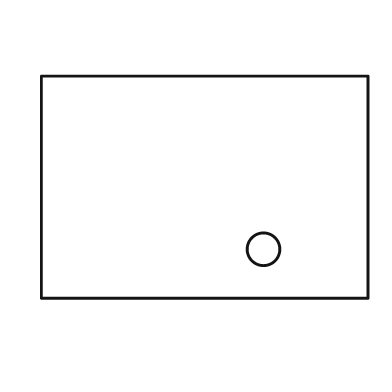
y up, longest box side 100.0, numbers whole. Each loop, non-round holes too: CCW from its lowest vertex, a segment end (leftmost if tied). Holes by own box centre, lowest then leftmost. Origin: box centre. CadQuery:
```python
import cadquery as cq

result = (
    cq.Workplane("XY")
    .moveTo(-50.0, -34.0)
    .lineTo(50.0, -34.0)
    .lineTo(50.0, 34.0)
    .lineTo(-50.0, 34.0)
    .close()
    .moveTo(18.0, -19.0)
    .circle(5.0)
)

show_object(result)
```